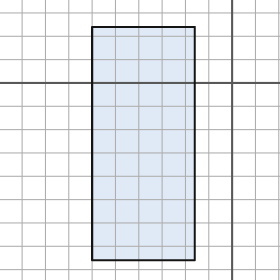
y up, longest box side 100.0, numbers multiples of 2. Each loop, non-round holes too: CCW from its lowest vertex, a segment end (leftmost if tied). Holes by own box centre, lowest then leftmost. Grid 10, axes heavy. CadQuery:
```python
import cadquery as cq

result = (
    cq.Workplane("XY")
    .moveTo(-60.0, -76.0)
    .lineTo(-16.0, -76.0)
    .lineTo(-16.0, 24.0)
    .lineTo(-60.0, 24.0)
    .close()
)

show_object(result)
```